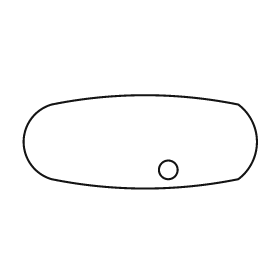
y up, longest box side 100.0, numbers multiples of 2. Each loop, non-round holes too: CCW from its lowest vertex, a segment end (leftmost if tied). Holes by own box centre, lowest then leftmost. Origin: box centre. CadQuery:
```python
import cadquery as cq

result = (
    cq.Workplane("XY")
    .moveTo(-38.0, -16.0)
    .threePointArc((2.0, -20.0), (42.0, -16.0))
    .threePointArc((50.0, 0.0), (42.0, 16.0))
    .threePointArc((2.0, 20.0), (-38.0, 16.0))
    .threePointArc((-50.0, 0.0), (-38.0, -16.0))
    .close()
    .moveTo(12.0, -12.0)
    .circle(4.0)
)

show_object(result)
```